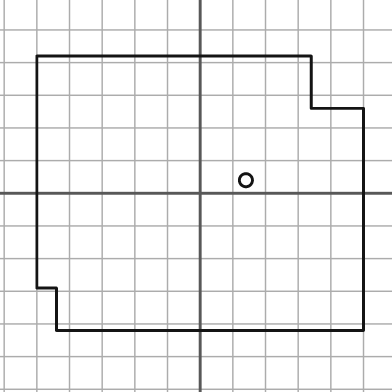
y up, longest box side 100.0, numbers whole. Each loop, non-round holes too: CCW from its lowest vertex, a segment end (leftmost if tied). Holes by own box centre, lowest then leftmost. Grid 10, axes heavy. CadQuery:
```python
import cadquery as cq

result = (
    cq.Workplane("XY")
    .moveTo(-44.0, -42.0)
    .lineTo(50.0, -42.0)
    .lineTo(50.0, 26.0)
    .lineTo(34.0, 26.0)
    .lineTo(34.0, 42.0)
    .lineTo(-50.0, 42.0)
    .lineTo(-50.0, -29.0)
    .lineTo(-44.0, -29.0)
    .close()
    .moveTo(14.0, 4.0)
    .circle(2.0)
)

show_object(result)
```